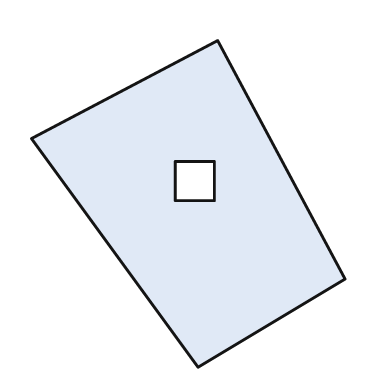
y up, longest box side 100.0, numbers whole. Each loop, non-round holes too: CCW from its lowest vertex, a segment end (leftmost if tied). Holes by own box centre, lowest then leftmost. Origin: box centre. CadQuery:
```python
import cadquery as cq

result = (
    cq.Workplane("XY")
    .moveTo(3.0, -50.0)
    .lineTo(48.0, -23.0)
    .lineTo(9.0, 50.0)
    .lineTo(-48.0, 20.0)
    .close()
    .moveTo(-4.0, 1.0)
    .lineTo(8.0, 1.0)
    .lineTo(8.0, 13.0)
    .lineTo(-4.0, 13.0)
    .close()
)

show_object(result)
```